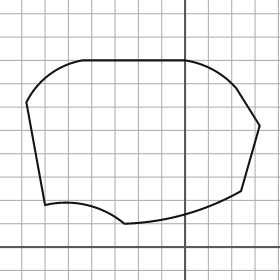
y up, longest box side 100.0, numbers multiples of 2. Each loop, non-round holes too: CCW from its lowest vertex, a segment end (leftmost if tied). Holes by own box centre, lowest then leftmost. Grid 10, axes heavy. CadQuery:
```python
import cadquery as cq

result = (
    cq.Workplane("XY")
    .moveTo(-26.0, 10.0)
    .threePointArc((0.0, 14.0), (24.0, 24.0))
    .lineTo(32.0, 52.0)
    .lineTo(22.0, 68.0)
    .threePointArc((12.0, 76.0), (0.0, 80.0))
    .lineTo(-44.0, 80.0)
    .threePointArc((-58.0, 74.0), (-68.0, 62.0))
    .lineTo(-60.0, 18.0)
    .threePointArc((-42.0, 18.0), (-26.0, 10.0))
    .close()
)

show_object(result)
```